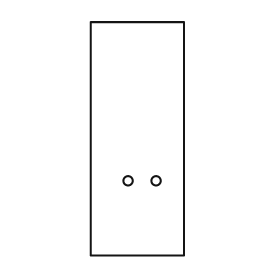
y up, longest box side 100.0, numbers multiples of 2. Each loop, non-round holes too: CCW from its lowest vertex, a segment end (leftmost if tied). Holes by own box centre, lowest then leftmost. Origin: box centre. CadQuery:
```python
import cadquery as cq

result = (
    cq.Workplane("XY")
    .moveTo(-20.0, -50.0)
    .lineTo(20.0, -50.0)
    .lineTo(20.0, 50.0)
    .lineTo(-20.0, 50.0)
    .close()
    .moveTo(-4.0, -18.0)
    .circle(2.0)
    .moveTo(8.0, -18.0)
    .circle(2.0)
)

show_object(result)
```